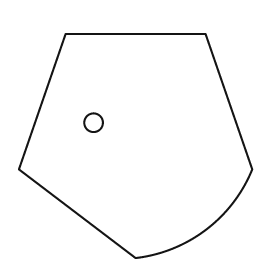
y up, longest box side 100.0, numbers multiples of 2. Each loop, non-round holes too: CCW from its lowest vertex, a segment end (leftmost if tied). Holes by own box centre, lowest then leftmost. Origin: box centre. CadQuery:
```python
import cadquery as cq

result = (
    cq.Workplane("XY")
    .moveTo(0.0, -48.0)
    .threePointArc((30.0, -36.0), (50.0, -10.0))
    .lineTo(30.0, 48.0)
    .lineTo(-30.0, 48.0)
    .lineTo(-50.0, -10.0)
    .close()
    .moveTo(-18.0, 10.0)
    .circle(4.0)
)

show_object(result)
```